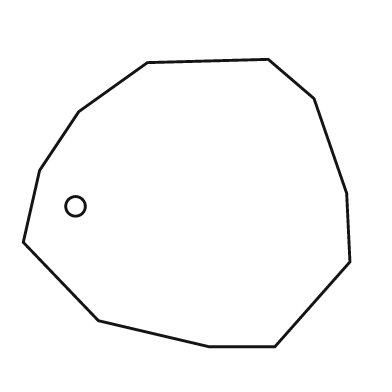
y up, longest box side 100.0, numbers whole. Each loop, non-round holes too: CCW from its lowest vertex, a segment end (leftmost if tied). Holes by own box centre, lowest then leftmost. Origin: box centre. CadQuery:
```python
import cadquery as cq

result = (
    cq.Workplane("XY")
    .moveTo(7.0, -44.0)
    .lineTo(27.0, -44.0)
    .lineTo(50.0, -18.0)
    .lineTo(49.0, 3.0)
    .lineTo(39.0, 32.0)
    .lineTo(25.0, 44.0)
    .lineTo(-12.0, 43.0)
    .lineTo(-33.0, 28.0)
    .lineTo(-45.0, 10.0)
    .lineTo(-50.0, -12.0)
    .lineTo(-27.0, -36.0)
    .close()
    .moveTo(-34.0, -1.0)
    .circle(3.0)
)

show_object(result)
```